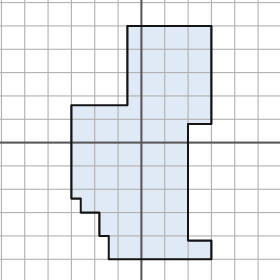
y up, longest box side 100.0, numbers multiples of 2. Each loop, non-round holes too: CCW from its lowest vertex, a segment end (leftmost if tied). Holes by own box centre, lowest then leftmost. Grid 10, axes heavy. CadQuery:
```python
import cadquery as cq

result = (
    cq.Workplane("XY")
    .moveTo(-14.0, -50.0)
    .lineTo(30.0, -50.0)
    .lineTo(30.0, -42.0)
    .lineTo(20.0, -42.0)
    .lineTo(20.0, 8.0)
    .lineTo(30.0, 8.0)
    .lineTo(30.0, 50.0)
    .lineTo(-6.0, 50.0)
    .lineTo(-6.0, 16.0)
    .lineTo(-30.0, 16.0)
    .lineTo(-30.0, -24.0)
    .lineTo(-26.0, -24.0)
    .lineTo(-26.0, -30.0)
    .lineTo(-18.0, -30.0)
    .lineTo(-18.0, -40.0)
    .lineTo(-14.0, -40.0)
    .close()
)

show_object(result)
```